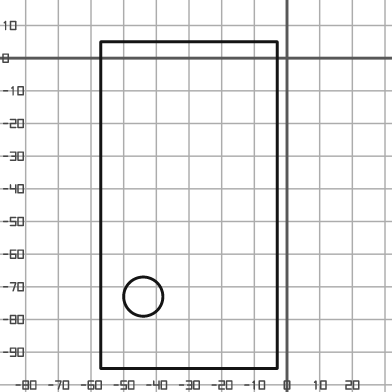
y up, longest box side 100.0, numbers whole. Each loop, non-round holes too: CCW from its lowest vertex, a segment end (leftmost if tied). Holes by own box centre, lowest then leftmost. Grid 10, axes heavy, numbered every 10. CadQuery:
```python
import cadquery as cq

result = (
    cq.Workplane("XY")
    .moveTo(-57.0, -95.0)
    .lineTo(-3.0, -95.0)
    .lineTo(-3.0, 5.0)
    .lineTo(-57.0, 5.0)
    .close()
    .moveTo(-44.0, -73.0)
    .circle(6.0)
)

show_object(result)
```